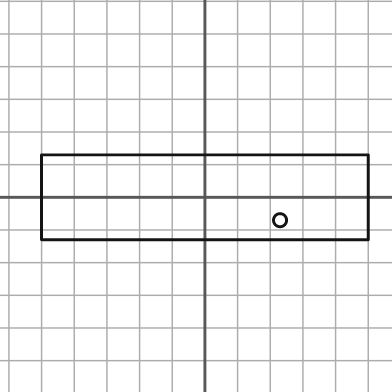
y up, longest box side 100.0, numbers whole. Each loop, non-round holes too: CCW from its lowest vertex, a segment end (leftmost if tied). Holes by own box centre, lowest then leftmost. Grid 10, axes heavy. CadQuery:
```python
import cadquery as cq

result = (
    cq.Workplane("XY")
    .moveTo(-50.0, -13.0)
    .lineTo(50.0, -13.0)
    .lineTo(50.0, 13.0)
    .lineTo(-50.0, 13.0)
    .close()
    .moveTo(23.0, -7.0)
    .circle(2.0)
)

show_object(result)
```